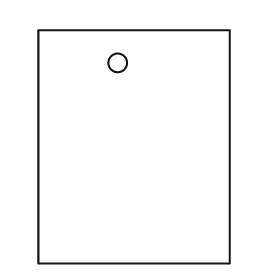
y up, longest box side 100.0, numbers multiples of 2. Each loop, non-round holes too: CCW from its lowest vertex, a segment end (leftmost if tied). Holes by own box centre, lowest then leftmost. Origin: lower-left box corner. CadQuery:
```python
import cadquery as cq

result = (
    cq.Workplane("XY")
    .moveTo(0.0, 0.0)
    .lineTo(82.0, 0.0)
    .lineTo(82.0, 100.0)
    .lineTo(0.0, 100.0)
    .close()
    .moveTo(34.0, 86.0)
    .circle(4.0)
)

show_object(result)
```